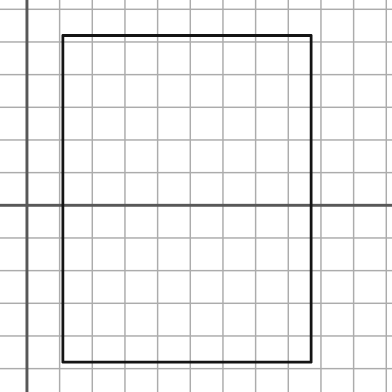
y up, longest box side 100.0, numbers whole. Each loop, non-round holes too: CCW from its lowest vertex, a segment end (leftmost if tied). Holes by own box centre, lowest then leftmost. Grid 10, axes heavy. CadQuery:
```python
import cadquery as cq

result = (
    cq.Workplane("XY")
    .moveTo(11.0, -48.0)
    .lineTo(87.0, -48.0)
    .lineTo(87.0, 52.0)
    .lineTo(11.0, 52.0)
    .close()
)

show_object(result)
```